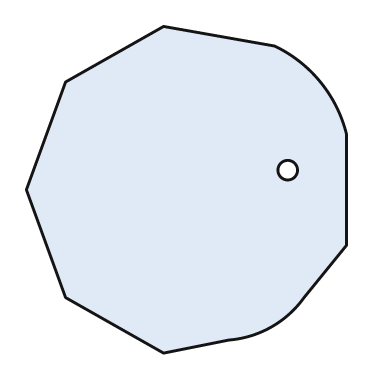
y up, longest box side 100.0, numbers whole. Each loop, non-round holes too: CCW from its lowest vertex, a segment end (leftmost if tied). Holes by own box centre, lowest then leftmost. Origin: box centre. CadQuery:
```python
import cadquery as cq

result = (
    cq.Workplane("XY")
    .moveTo(-7.0, -50.0)
    .lineTo(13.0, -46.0)
    .threePointArc((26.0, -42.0), (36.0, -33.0))
    .lineTo(49.0, -17.0)
    .lineTo(49.0, 17.0)
    .threePointArc((41.0, 33.0), (27.0, 44.0))
    .lineTo(-7.0, 50.0)
    .lineTo(-37.0, 33.0)
    .lineTo(-49.0, 0.0)
    .lineTo(-37.0, -33.0)
    .close()
    .moveTo(31.0, 6.0)
    .circle(3.0)
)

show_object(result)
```